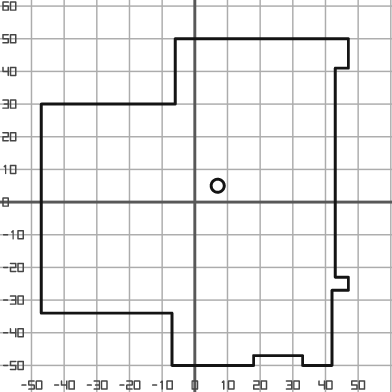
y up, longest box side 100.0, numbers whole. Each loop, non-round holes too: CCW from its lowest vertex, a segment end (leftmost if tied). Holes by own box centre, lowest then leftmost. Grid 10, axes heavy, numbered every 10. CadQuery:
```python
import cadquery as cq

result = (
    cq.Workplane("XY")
    .moveTo(-7.0, -50.0)
    .lineTo(18.0, -50.0)
    .lineTo(18.0, -47.0)
    .lineTo(33.0, -47.0)
    .lineTo(33.0, -50.0)
    .lineTo(42.0, -50.0)
    .lineTo(42.0, -27.0)
    .lineTo(47.0, -27.0)
    .lineTo(47.0, -23.0)
    .lineTo(43.0, -23.0)
    .lineTo(43.0, 41.0)
    .lineTo(47.0, 41.0)
    .lineTo(47.0, 50.0)
    .lineTo(-6.0, 50.0)
    .lineTo(-6.0, 30.0)
    .lineTo(-47.0, 30.0)
    .lineTo(-47.0, -34.0)
    .lineTo(-7.0, -34.0)
    .close()
    .moveTo(7.0, 5.0)
    .circle(2.0)
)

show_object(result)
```